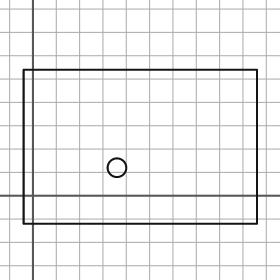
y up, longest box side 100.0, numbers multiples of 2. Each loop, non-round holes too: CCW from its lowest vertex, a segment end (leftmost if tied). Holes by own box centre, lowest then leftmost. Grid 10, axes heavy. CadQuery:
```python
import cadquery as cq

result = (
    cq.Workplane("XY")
    .moveTo(-4.0, -12.0)
    .lineTo(96.0, -12.0)
    .lineTo(96.0, 54.0)
    .lineTo(-4.0, 54.0)
    .close()
    .moveTo(36.0, 12.0)
    .circle(4.0)
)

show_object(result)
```